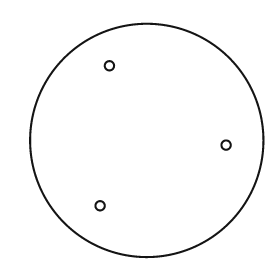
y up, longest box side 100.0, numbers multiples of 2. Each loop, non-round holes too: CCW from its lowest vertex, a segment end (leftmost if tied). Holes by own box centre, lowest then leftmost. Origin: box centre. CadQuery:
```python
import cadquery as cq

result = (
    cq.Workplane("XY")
    .moveTo(0.0, 0.0)
    .circle(50.0)
    .moveTo(-20.0, -28.0)
    .circle(2.0)
    .moveTo(34.0, -2.0)
    .circle(2.0)
    .moveTo(-16.0, 32.0)
    .circle(2.0)
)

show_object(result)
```